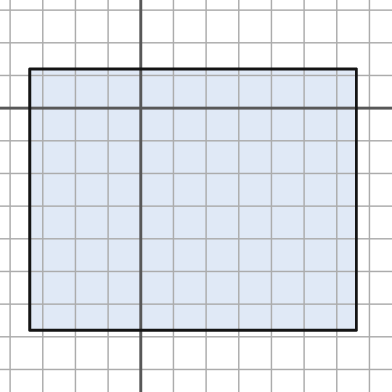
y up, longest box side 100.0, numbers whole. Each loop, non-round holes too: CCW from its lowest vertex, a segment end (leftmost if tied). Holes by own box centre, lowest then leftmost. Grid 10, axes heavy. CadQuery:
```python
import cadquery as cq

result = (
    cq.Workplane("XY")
    .moveTo(-34.0, -68.0)
    .lineTo(66.0, -68.0)
    .lineTo(66.0, 12.0)
    .lineTo(-34.0, 12.0)
    .close()
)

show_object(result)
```